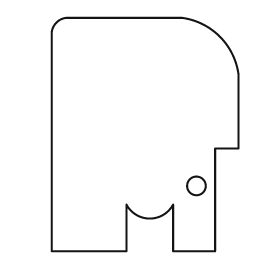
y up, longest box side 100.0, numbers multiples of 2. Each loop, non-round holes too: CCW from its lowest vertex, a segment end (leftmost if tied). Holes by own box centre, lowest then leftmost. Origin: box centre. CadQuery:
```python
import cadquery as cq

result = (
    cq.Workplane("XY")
    .moveTo(-40.0, -50.0)
    .lineTo(-8.0, -50.0)
    .lineTo(-8.0, -30.0)
    .threePointArc((2.0, -36.0), (12.0, -30.0))
    .lineTo(12.0, -50.0)
    .lineTo(30.0, -50.0)
    .lineTo(30.0, -6.0)
    .lineTo(40.0, -6.0)
    .lineTo(40.0, 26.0)
    .threePointArc((32.0, 42.0), (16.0, 50.0))
    .lineTo(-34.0, 50.0)
    .threePointArc((-38.0, 48.0), (-40.0, 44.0))
    .close()
    .moveTo(22.0, -22.0)
    .circle(4.0)
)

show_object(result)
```